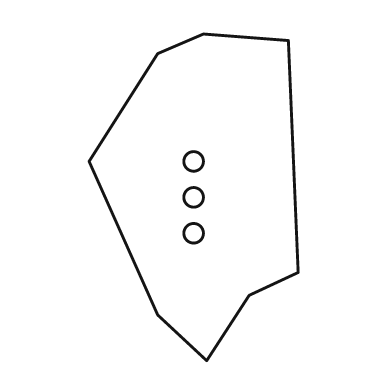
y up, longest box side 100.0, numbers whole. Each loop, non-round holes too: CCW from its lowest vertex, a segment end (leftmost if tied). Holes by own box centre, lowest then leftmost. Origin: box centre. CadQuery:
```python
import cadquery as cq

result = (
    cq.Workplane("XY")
    .moveTo(4.0, -50.0)
    .lineTo(17.0, -30.0)
    .lineTo(32.0, -23.0)
    .lineTo(29.0, 48.0)
    .lineTo(3.0, 50.0)
    .lineTo(-11.0, 44.0)
    .lineTo(-32.0, 11.0)
    .lineTo(-11.0, -36.0)
    .close()
    .moveTo(0.0, -11.0)
    .circle(3.0)
    .moveTo(0.0, 0.0)
    .circle(3.0)
    .moveTo(0.0, 11.0)
    .circle(3.0)
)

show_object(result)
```